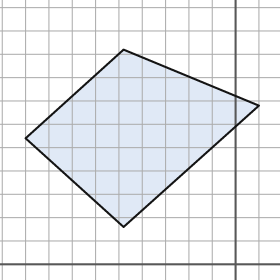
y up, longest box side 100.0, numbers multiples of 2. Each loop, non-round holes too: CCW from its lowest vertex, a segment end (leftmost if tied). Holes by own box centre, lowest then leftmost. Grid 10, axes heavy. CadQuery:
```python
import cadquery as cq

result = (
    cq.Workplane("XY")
    .moveTo(-48.0, 16.0)
    .lineTo(10.0, 68.0)
    .lineTo(-48.0, 92.0)
    .lineTo(-90.0, 54.0)
    .close()
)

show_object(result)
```